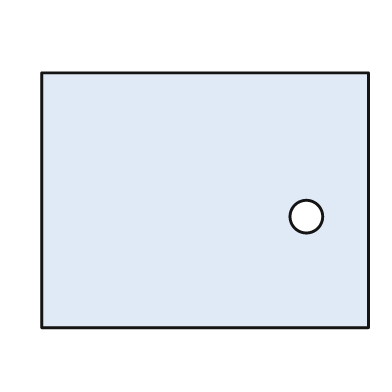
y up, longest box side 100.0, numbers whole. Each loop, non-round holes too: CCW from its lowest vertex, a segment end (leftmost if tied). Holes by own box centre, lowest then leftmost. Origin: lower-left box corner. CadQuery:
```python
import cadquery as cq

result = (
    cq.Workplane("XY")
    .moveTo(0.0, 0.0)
    .lineTo(100.0, 0.0)
    .lineTo(100.0, 78.0)
    .lineTo(0.0, 78.0)
    .close()
    .moveTo(81.0, 34.0)
    .circle(5.0)
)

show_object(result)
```